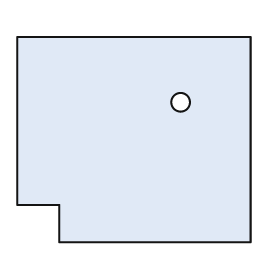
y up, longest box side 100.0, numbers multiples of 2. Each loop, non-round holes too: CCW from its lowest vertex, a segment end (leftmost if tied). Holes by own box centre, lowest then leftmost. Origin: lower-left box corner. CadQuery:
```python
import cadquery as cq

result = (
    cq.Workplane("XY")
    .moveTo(18.0, 0.0)
    .lineTo(100.0, 0.0)
    .lineTo(100.0, 88.0)
    .lineTo(0.0, 88.0)
    .lineTo(0.0, 16.0)
    .lineTo(18.0, 16.0)
    .close()
    .moveTo(70.0, 60.0)
    .circle(4.0)
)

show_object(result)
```